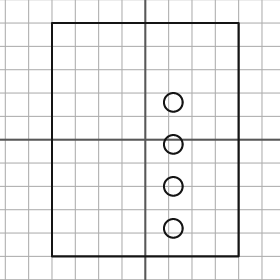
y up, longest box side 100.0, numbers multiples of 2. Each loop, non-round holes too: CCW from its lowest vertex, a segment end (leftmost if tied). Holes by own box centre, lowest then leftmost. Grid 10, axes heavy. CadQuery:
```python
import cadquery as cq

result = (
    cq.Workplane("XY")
    .moveTo(-40.0, -50.0)
    .lineTo(40.0, -50.0)
    .lineTo(40.0, 50.0)
    .lineTo(-40.0, 50.0)
    .close()
    .moveTo(12.0, -38.0)
    .circle(4.0)
    .moveTo(12.0, -20.0)
    .circle(4.0)
    .moveTo(12.0, -2.0)
    .circle(4.0)
    .moveTo(12.0, 16.0)
    .circle(4.0)
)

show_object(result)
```